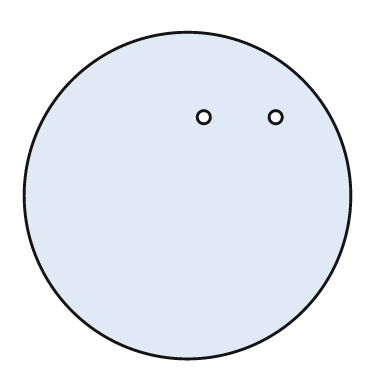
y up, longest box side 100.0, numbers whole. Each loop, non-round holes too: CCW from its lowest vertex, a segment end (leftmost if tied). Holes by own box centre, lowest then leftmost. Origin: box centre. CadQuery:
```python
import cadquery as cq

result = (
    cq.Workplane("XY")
    .moveTo(0.0, 0.0)
    .circle(50.0)
    .moveTo(5.0, 24.0)
    .circle(2.0)
    .moveTo(27.0, 24.0)
    .circle(2.0)
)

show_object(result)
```